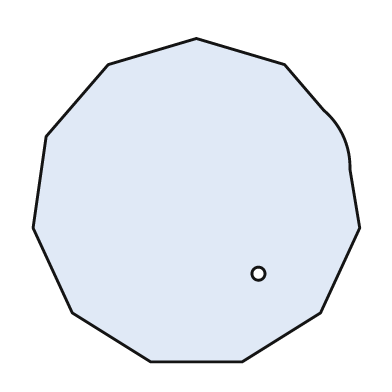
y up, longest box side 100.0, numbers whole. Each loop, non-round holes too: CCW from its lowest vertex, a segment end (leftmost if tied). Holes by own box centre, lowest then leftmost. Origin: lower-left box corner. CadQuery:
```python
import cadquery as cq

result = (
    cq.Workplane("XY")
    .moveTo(36.0, 0.0)
    .lineTo(64.0, 0.0)
    .lineTo(88.0, 15.0)
    .lineTo(100.0, 41.0)
    .lineTo(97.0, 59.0)
    .threePointArc((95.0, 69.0), (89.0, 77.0))
    .lineTo(77.0, 91.0)
    .lineTo(50.0, 99.0)
    .lineTo(23.0, 91.0)
    .lineTo(4.0, 69.0)
    .lineTo(0.0, 41.0)
    .lineTo(12.0, 15.0)
    .close()
    .moveTo(69.0, 27.0)
    .circle(2.0)
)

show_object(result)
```